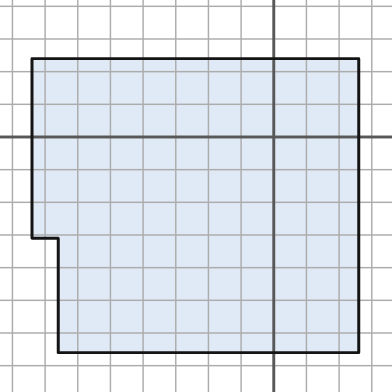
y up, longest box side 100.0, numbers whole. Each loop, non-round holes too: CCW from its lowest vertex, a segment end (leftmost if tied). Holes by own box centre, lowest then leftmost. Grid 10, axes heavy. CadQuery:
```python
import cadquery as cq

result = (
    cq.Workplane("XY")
    .moveTo(-66.0, -66.0)
    .lineTo(26.0, -66.0)
    .lineTo(26.0, 24.0)
    .lineTo(-74.0, 24.0)
    .lineTo(-74.0, -31.0)
    .lineTo(-66.0, -31.0)
    .close()
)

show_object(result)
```